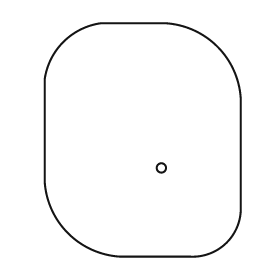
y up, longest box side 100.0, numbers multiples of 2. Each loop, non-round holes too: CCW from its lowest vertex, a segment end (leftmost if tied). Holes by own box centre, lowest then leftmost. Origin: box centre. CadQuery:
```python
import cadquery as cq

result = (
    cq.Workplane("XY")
    .moveTo(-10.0, -50.0)
    .lineTo(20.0, -50.0)
    .threePointArc((36.0, -44.0), (42.0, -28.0))
    .lineTo(42.0, 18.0)
    .threePointArc((32.0, 40.0), (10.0, 50.0))
    .lineTo(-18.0, 50.0)
    .threePointArc((-34.0, 42.0), (-42.0, 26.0))
    .lineTo(-42.0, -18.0)
    .threePointArc((-32.0, -40.0), (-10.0, -50.0))
    .close()
    .moveTo(8.0, -12.0)
    .circle(2.0)
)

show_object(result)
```